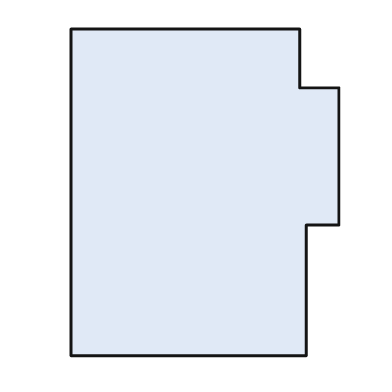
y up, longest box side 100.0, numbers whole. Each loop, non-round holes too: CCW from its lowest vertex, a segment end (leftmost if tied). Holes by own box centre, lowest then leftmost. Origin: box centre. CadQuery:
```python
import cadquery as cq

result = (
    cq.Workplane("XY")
    .moveTo(-41.0, -50.0)
    .lineTo(31.0, -50.0)
    .lineTo(31.0, -10.0)
    .lineTo(41.0, -10.0)
    .lineTo(41.0, 32.0)
    .lineTo(29.0, 32.0)
    .lineTo(29.0, 50.0)
    .lineTo(-41.0, 50.0)
    .close()
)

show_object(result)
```